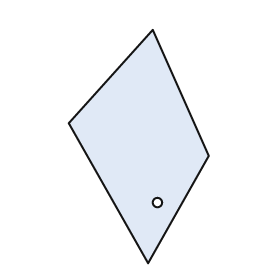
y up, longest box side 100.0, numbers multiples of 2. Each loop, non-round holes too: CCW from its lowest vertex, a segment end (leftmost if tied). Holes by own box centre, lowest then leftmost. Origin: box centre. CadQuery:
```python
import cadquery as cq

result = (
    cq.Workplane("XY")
    .moveTo(4.0, -50.0)
    .lineTo(30.0, -4.0)
    .lineTo(6.0, 50.0)
    .lineTo(-30.0, 10.0)
    .close()
    .moveTo(8.0, -24.0)
    .circle(2.0)
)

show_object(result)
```